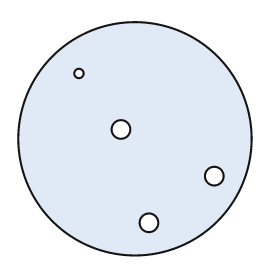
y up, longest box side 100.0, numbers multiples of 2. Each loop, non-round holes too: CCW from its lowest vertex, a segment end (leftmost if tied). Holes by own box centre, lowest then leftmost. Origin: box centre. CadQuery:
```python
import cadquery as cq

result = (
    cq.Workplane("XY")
    .moveTo(0.0, 0.0)
    .circle(50.0)
    .moveTo(6.0, -36.0)
    .circle(4.0)
    .moveTo(34.0, -16.0)
    .circle(4.0)
    .moveTo(-6.0, 4.0)
    .circle(4.0)
    .moveTo(-24.0, 28.0)
    .circle(2.0)
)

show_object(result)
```